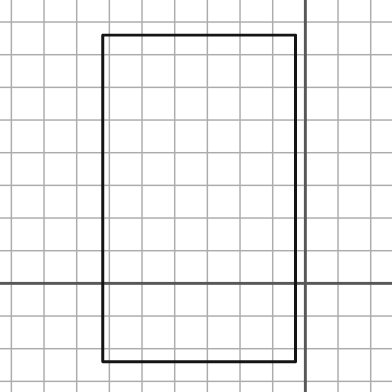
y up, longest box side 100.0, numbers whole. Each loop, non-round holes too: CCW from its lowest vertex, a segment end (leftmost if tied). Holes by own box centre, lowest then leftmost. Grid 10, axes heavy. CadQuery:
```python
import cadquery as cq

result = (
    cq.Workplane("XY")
    .moveTo(-62.0, -24.0)
    .lineTo(-3.0, -24.0)
    .lineTo(-3.0, 76.0)
    .lineTo(-62.0, 76.0)
    .close()
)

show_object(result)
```